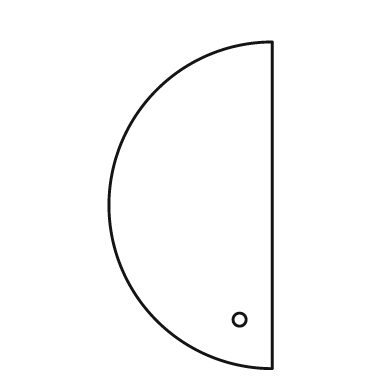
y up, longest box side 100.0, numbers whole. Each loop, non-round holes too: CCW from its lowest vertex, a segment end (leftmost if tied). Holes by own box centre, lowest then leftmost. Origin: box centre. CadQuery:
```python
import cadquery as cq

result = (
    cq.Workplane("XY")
    .moveTo(25.0, -50.0)
    .lineTo(25.0, 50.0)
    .threePointArc((-25.0, 0.0), (25.0, -50.0))
    .close()
    .moveTo(15.0, -35.0)
    .circle(2.0)
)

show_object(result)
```